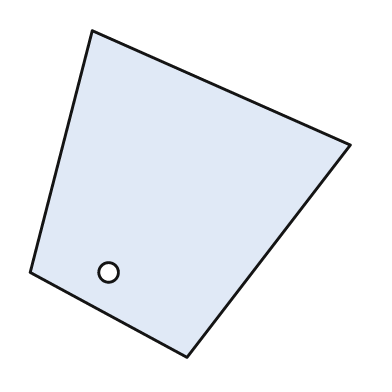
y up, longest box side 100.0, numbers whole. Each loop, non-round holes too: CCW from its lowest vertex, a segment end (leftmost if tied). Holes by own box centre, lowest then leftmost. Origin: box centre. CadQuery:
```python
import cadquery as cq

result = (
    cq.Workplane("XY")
    .moveTo(-1.0, -50.0)
    .lineTo(49.0, 15.0)
    .lineTo(-30.0, 50.0)
    .lineTo(-49.0, -24.0)
    .close()
    .moveTo(-25.0, -24.0)
    .circle(3.0)
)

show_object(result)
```